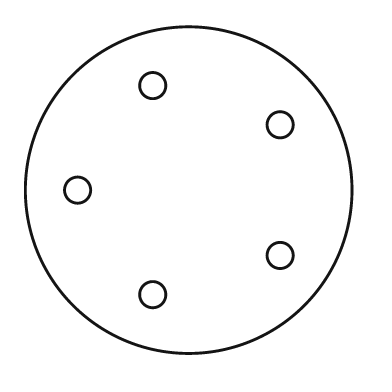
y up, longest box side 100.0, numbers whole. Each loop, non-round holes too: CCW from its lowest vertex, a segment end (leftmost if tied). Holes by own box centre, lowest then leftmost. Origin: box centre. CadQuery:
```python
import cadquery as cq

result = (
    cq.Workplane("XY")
    .moveTo(0.0, 0.0)
    .circle(50.0)
    .moveTo(-11.0, -32.0)
    .circle(4.0)
    .moveTo(28.0, -20.0)
    .circle(4.0)
    .moveTo(-34.0, 0.0)
    .circle(4.0)
    .moveTo(28.0, 20.0)
    .circle(4.0)
    .moveTo(-11.0, 32.0)
    .circle(4.0)
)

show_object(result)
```